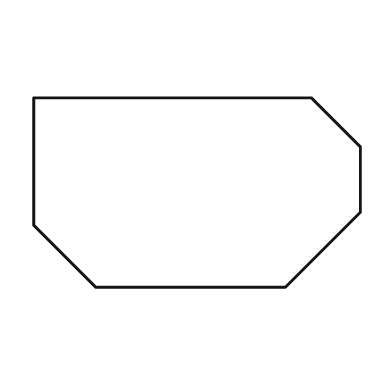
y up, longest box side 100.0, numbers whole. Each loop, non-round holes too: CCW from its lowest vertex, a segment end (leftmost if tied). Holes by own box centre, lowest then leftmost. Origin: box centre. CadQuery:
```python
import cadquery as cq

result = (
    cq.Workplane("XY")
    .moveTo(-31.0, -29.0)
    .lineTo(27.0, -29.0)
    .lineTo(50.0, -6.0)
    .lineTo(50.0, 14.0)
    .lineTo(35.0, 29.0)
    .lineTo(-50.0, 29.0)
    .lineTo(-50.0, -10.0)
    .close()
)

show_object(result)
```